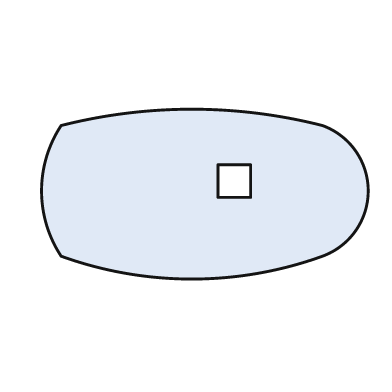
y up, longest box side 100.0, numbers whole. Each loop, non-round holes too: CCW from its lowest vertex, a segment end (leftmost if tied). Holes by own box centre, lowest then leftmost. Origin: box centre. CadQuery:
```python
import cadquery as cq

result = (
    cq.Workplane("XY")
    .moveTo(-44.0, -19.0)
    .threePointArc((-4.0, -26.0), (36.0, -19.0))
    .threePointArc((50.0, 1.0), (36.0, 21.0))
    .threePointArc((-4.0, 26.0), (-44.0, 21.0))
    .threePointArc((-50.0, 1.0), (-44.0, -19.0))
    .close()
    .moveTo(4.0, -1.0)
    .lineTo(14.0, -1.0)
    .lineTo(14.0, 9.0)
    .lineTo(4.0, 9.0)
    .close()
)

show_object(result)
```